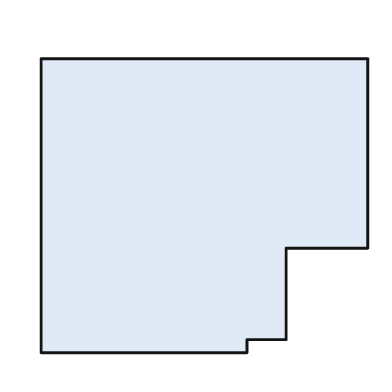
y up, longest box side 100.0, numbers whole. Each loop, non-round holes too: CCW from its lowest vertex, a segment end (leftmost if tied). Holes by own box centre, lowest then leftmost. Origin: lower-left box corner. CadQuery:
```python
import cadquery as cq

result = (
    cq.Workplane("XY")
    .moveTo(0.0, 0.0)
    .lineTo(63.0, 0.0)
    .lineTo(63.0, 4.0)
    .lineTo(75.0, 4.0)
    .lineTo(75.0, 32.0)
    .lineTo(100.0, 32.0)
    .lineTo(100.0, 90.0)
    .lineTo(0.0, 90.0)
    .close()
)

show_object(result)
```